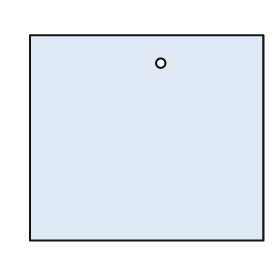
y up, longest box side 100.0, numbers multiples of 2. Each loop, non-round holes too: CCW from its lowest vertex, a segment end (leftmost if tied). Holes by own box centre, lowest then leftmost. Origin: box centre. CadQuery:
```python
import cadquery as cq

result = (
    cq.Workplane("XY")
    .moveTo(-50.0, -44.0)
    .lineTo(50.0, -44.0)
    .lineTo(50.0, 44.0)
    .lineTo(-50.0, 44.0)
    .close()
    .moveTo(6.0, 32.0)
    .circle(2.0)
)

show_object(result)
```